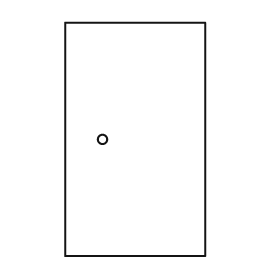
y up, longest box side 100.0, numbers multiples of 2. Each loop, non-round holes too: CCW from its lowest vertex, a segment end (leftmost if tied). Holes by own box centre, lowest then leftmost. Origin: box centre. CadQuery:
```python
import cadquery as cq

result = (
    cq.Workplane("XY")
    .moveTo(-30.0, -50.0)
    .lineTo(30.0, -50.0)
    .lineTo(30.0, 50.0)
    .lineTo(-30.0, 50.0)
    .close()
    .moveTo(-14.0, 0.0)
    .circle(2.0)
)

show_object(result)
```